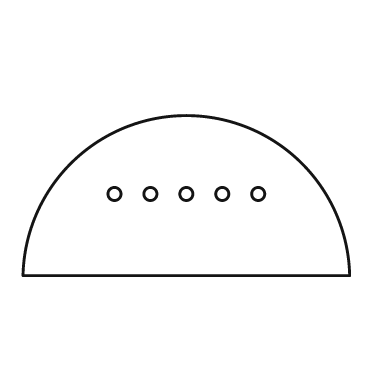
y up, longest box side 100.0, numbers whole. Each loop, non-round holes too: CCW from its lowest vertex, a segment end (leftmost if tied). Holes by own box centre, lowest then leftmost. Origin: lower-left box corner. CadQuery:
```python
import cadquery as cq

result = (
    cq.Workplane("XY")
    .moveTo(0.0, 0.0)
    .lineTo(100.0, 0.0)
    .threePointArc((50.0, 49.0), (0.0, 0.0))
    .close()
    .moveTo(28.0, 25.0)
    .circle(2.0)
    .moveTo(39.0, 25.0)
    .circle(2.0)
    .moveTo(50.0, 25.0)
    .circle(2.0)
    .moveTo(61.0, 25.0)
    .circle(2.0)
    .moveTo(72.0, 25.0)
    .circle(2.0)
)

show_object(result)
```